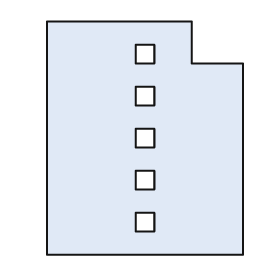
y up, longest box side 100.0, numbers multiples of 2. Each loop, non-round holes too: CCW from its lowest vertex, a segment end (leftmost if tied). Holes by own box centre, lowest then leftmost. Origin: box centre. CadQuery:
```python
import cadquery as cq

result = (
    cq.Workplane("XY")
    .moveTo(-42.0, -50.0)
    .lineTo(42.0, -50.0)
    .lineTo(42.0, 32.0)
    .lineTo(20.0, 32.0)
    .lineTo(20.0, 50.0)
    .lineTo(-42.0, 50.0)
    .close()
    .moveTo(-4.0, -40.0)
    .lineTo(4.0, -40.0)
    .lineTo(4.0, -32.0)
    .lineTo(-4.0, -32.0)
    .close()
    .moveTo(-4.0, -22.0)
    .lineTo(4.0, -22.0)
    .lineTo(4.0, -14.0)
    .lineTo(-4.0, -14.0)
    .close()
    .moveTo(-4.0, -4.0)
    .lineTo(4.0, -4.0)
    .lineTo(4.0, 4.0)
    .lineTo(-4.0, 4.0)
    .close()
    .moveTo(-4.0, 14.0)
    .lineTo(4.0, 14.0)
    .lineTo(4.0, 22.0)
    .lineTo(-4.0, 22.0)
    .close()
    .moveTo(-4.0, 32.0)
    .lineTo(4.0, 32.0)
    .lineTo(4.0, 40.0)
    .lineTo(-4.0, 40.0)
    .close()
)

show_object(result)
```